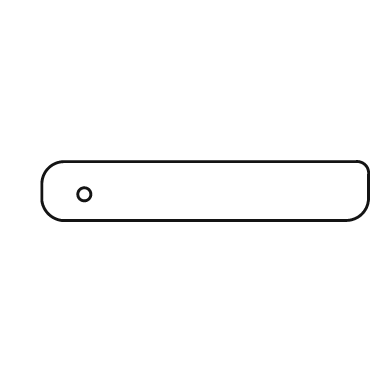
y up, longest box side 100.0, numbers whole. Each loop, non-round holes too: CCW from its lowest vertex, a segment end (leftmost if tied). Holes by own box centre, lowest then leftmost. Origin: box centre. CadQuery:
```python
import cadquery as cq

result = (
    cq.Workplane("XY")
    .moveTo(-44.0, -9.0)
    .lineTo(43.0, -9.0)
    .threePointArc((48.0, -7.0), (50.0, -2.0))
    .lineTo(50.0, 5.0)
    .threePointArc((49.0, 8.0), (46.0, 9.0))
    .lineTo(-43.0, 9.0)
    .threePointArc((-48.0, 7.0), (-50.0, 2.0))
    .lineTo(-50.0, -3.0)
    .threePointArc((-48.0, -7.0), (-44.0, -9.0))
    .close()
    .moveTo(-37.0, -1.0)
    .circle(2.0)
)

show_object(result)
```